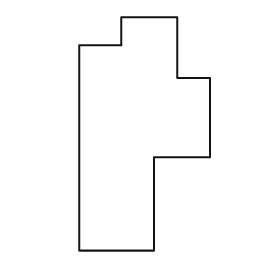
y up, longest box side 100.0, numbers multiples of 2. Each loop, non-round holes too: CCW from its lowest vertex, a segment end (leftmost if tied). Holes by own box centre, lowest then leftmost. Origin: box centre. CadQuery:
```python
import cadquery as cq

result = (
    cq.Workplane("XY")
    .moveTo(-28.0, -50.0)
    .lineTo(4.0, -50.0)
    .lineTo(4.0, -10.0)
    .lineTo(28.0, -10.0)
    .lineTo(28.0, 24.0)
    .lineTo(14.0, 24.0)
    .lineTo(14.0, 50.0)
    .lineTo(-10.0, 50.0)
    .lineTo(-10.0, 38.0)
    .lineTo(-28.0, 38.0)
    .close()
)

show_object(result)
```